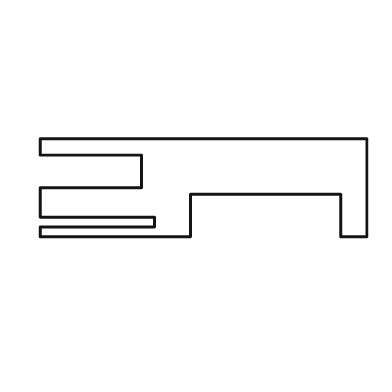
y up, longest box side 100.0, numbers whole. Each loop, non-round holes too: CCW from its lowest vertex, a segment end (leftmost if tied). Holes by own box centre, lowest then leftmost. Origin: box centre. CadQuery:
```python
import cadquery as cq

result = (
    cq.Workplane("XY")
    .moveTo(-50.0, -15.0)
    .lineTo(-4.0, -15.0)
    .lineTo(-4.0, -2.0)
    .lineTo(42.0, -2.0)
    .lineTo(42.0, -15.0)
    .lineTo(50.0, -15.0)
    .lineTo(50.0, 15.0)
    .lineTo(-50.0, 15.0)
    .lineTo(-50.0, 10.0)
    .lineTo(-19.0, 10.0)
    .lineTo(-19.0, 0.0)
    .lineTo(-50.0, 0.0)
    .lineTo(-50.0, -9.0)
    .lineTo(-15.0, -9.0)
    .lineTo(-15.0, -12.0)
    .lineTo(-50.0, -12.0)
    .close()
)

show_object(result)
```